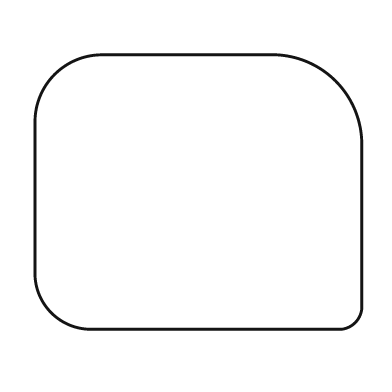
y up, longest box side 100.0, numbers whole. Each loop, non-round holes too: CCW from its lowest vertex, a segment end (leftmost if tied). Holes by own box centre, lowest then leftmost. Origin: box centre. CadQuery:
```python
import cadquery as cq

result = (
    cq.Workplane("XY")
    .moveTo(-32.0, -42.0)
    .lineTo(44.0, -42.0)
    .threePointArc((48.0, -40.0), (50.0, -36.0))
    .lineTo(50.0, 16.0)
    .threePointArc((42.0, 34.0), (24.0, 42.0))
    .lineTo(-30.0, 42.0)
    .threePointArc((-44.0, 36.0), (-50.0, 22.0))
    .lineTo(-50.0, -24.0)
    .threePointArc((-45.0, -37.0), (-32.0, -42.0))
    .close()
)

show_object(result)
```